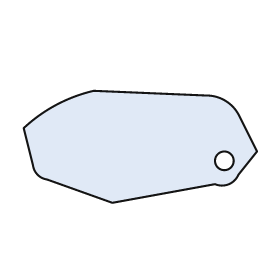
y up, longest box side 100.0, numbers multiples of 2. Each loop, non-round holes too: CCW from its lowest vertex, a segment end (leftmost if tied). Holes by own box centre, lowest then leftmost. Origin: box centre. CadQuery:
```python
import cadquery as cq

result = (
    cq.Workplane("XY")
    .moveTo(-12.0, -24.0)
    .lineTo(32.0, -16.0)
    .threePointArc((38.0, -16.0), (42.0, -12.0))
    .lineTo(50.0, -2.0)
    .lineTo(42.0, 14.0)
    .threePointArc((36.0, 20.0), (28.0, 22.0))
    .lineTo(-20.0, 24.0)
    .threePointArc((-36.0, 18.0), (-50.0, 8.0))
    .lineTo(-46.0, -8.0)
    .threePointArc((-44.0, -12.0), (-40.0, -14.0))
    .close()
    .moveTo(36.0, -6.0)
    .circle(4.0)
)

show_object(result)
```